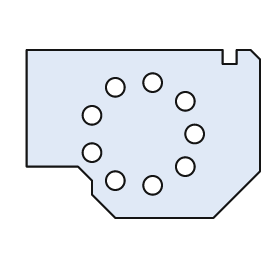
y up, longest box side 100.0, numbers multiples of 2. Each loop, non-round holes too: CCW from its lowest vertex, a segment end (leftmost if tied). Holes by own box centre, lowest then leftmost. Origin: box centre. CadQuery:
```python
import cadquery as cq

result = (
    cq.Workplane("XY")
    .moveTo(-12.0, -36.0)
    .lineTo(30.0, -36.0)
    .lineTo(50.0, -16.0)
    .lineTo(50.0, 32.0)
    .lineTo(46.0, 36.0)
    .lineTo(40.0, 36.0)
    .lineTo(40.0, 30.0)
    .lineTo(34.0, 30.0)
    .lineTo(34.0, 36.0)
    .lineTo(-50.0, 36.0)
    .lineTo(-50.0, -14.0)
    .lineTo(-28.0, -14.0)
    .lineTo(-22.0, -20.0)
    .lineTo(-22.0, -26.0)
    .close()
    .moveTo(4.0, -22.0)
    .circle(4.0)
    .moveTo(-12.0, -20.0)
    .circle(4.0)
    .moveTo(18.0, -14.0)
    .circle(4.0)
    .moveTo(-22.0, -8.0)
    .circle(4.0)
    .moveTo(22.0, 0.0)
    .circle(4.0)
    .moveTo(-22.0, 8.0)
    .circle(4.0)
    .moveTo(18.0, 14.0)
    .circle(4.0)
    .moveTo(-12.0, 20.0)
    .circle(4.0)
    .moveTo(4.0, 22.0)
    .circle(4.0)
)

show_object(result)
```